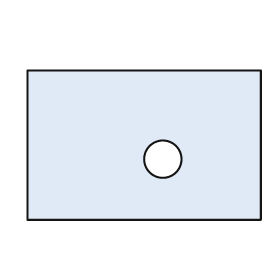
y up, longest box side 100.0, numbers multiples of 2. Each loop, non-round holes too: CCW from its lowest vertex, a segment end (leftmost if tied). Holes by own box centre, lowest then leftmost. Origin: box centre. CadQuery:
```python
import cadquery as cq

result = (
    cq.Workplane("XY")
    .moveTo(-50.0, -32.0)
    .lineTo(50.0, -32.0)
    .lineTo(50.0, 32.0)
    .lineTo(-50.0, 32.0)
    .close()
    .moveTo(8.0, -6.0)
    .circle(8.0)
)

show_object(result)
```